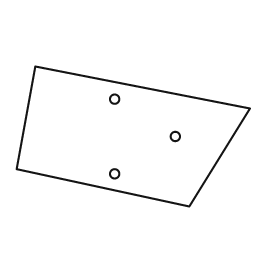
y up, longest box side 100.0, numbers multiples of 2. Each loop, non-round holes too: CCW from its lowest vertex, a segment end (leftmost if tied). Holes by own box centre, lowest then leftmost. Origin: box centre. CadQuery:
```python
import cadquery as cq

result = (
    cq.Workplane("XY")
    .moveTo(24.0, -30.0)
    .lineTo(50.0, 12.0)
    .lineTo(-42.0, 30.0)
    .lineTo(-50.0, -14.0)
    .close()
    .moveTo(-8.0, -16.0)
    .circle(2.0)
    .moveTo(18.0, 0.0)
    .circle(2.0)
    .moveTo(-8.0, 16.0)
    .circle(2.0)
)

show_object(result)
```